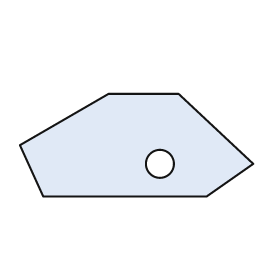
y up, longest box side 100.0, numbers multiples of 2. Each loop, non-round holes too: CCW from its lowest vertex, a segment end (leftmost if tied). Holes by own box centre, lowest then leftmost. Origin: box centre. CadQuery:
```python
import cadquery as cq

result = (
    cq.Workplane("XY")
    .moveTo(-40.0, -22.0)
    .lineTo(30.0, -22.0)
    .lineTo(50.0, -8.0)
    .lineTo(18.0, 22.0)
    .lineTo(-12.0, 22.0)
    .lineTo(-50.0, 0.0)
    .close()
    .moveTo(10.0, -8.0)
    .circle(6.0)
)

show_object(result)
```